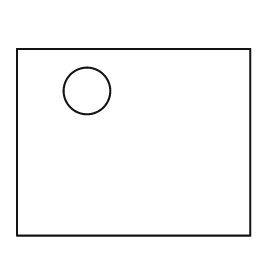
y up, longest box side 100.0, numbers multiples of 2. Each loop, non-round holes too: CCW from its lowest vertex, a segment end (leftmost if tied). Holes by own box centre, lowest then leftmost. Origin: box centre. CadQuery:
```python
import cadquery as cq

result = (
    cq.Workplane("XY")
    .moveTo(-50.0, -40.0)
    .lineTo(50.0, -40.0)
    .lineTo(50.0, 40.0)
    .lineTo(-50.0, 40.0)
    .close()
    .moveTo(-20.0, 22.0)
    .circle(10.0)
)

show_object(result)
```